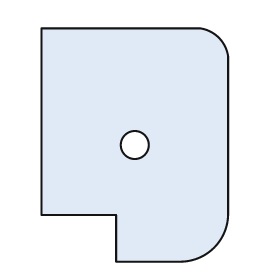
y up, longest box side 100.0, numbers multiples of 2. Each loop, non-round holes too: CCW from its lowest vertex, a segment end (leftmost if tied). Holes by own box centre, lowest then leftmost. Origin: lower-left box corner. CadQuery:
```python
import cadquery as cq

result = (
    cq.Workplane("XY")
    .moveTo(32.0, 0.0)
    .lineTo(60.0, 0.0)
    .threePointArc((74.0, 6.0), (80.0, 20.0))
    .lineTo(80.0, 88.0)
    .threePointArc((76.0, 96.0), (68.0, 100.0))
    .lineTo(0.0, 100.0)
    .lineTo(0.0, 20.0)
    .lineTo(32.0, 20.0)
    .close()
    .moveTo(40.0, 50.0)
    .circle(6.0)
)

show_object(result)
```